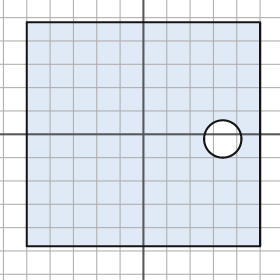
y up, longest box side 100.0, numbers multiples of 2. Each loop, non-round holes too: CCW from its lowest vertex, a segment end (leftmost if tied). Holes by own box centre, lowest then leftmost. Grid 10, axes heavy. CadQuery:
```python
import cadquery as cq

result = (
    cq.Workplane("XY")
    .moveTo(-50.0, -48.0)
    .lineTo(50.0, -48.0)
    .lineTo(50.0, 48.0)
    .lineTo(-50.0, 48.0)
    .close()
    .moveTo(34.0, -2.0)
    .circle(8.0)
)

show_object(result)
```